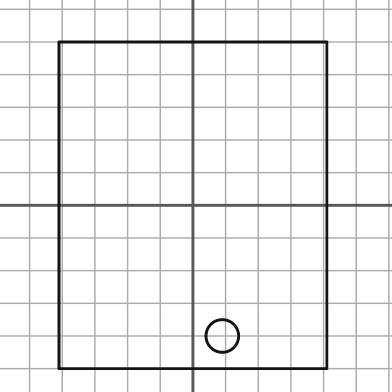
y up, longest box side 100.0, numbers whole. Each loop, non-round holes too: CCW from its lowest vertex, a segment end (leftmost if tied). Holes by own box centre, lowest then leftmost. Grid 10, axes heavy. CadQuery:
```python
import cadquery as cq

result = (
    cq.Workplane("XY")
    .moveTo(-41.0, -50.0)
    .lineTo(41.0, -50.0)
    .lineTo(41.0, 50.0)
    .lineTo(-41.0, 50.0)
    .close()
    .moveTo(9.0, -40.0)
    .circle(5.0)
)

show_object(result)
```